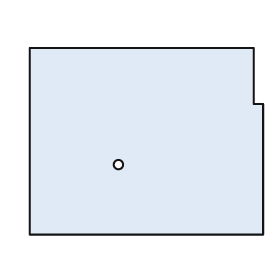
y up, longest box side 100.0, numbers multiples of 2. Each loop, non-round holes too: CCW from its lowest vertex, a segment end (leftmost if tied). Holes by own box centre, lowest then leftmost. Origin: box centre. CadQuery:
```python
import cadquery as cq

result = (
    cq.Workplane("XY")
    .moveTo(-50.0, -40.0)
    .lineTo(50.0, -40.0)
    .lineTo(50.0, 16.0)
    .lineTo(46.0, 16.0)
    .lineTo(46.0, 40.0)
    .lineTo(-50.0, 40.0)
    .close()
    .moveTo(-12.0, -10.0)
    .circle(2.0)
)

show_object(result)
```